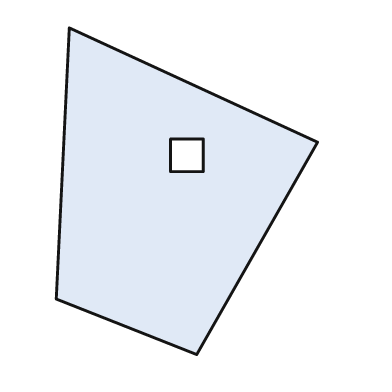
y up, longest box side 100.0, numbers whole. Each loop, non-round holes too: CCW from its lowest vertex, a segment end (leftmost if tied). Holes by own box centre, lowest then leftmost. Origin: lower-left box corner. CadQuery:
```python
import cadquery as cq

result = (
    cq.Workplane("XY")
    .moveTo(43.0, 0.0)
    .lineTo(80.0, 65.0)
    .lineTo(4.0, 100.0)
    .lineTo(0.0, 17.0)
    .close()
    .moveTo(35.0, 56.0)
    .lineTo(45.0, 56.0)
    .lineTo(45.0, 66.0)
    .lineTo(35.0, 66.0)
    .close()
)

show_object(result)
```